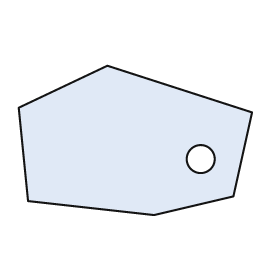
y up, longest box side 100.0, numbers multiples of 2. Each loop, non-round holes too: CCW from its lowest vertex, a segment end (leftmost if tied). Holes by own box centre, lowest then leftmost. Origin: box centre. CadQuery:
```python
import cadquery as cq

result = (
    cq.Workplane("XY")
    .moveTo(8.0, -32.0)
    .lineTo(42.0, -24.0)
    .lineTo(50.0, 12.0)
    .lineTo(-12.0, 32.0)
    .lineTo(-50.0, 14.0)
    .lineTo(-46.0, -26.0)
    .close()
    .moveTo(28.0, -8.0)
    .circle(6.0)
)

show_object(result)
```